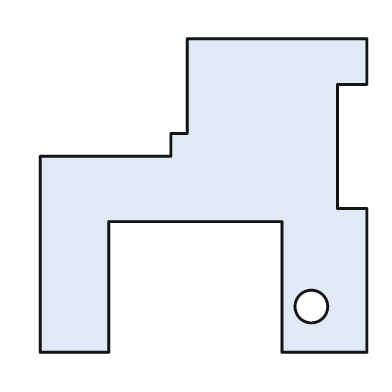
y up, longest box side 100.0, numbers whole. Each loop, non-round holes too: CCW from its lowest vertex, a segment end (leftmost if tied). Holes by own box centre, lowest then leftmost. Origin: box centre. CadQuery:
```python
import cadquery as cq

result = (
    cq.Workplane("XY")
    .moveTo(-50.0, -48.0)
    .lineTo(-29.0, -48.0)
    .lineTo(-29.0, -8.0)
    .lineTo(24.0, -8.0)
    .lineTo(24.0, -48.0)
    .lineTo(50.0, -48.0)
    .lineTo(50.0, -4.0)
    .lineTo(41.0, -4.0)
    .lineTo(41.0, 34.0)
    .lineTo(50.0, 34.0)
    .lineTo(50.0, 48.0)
    .lineTo(-5.0, 48.0)
    .lineTo(-5.0, 19.0)
    .lineTo(-10.0, 19.0)
    .lineTo(-10.0, 12.0)
    .lineTo(-50.0, 12.0)
    .close()
    .moveTo(33.0, -34.0)
    .circle(5.0)
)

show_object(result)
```